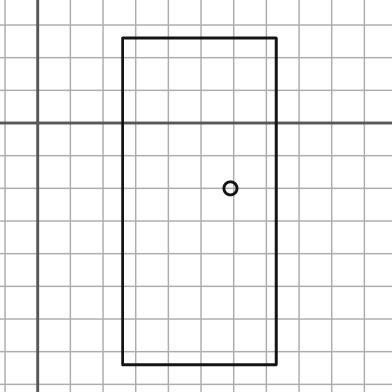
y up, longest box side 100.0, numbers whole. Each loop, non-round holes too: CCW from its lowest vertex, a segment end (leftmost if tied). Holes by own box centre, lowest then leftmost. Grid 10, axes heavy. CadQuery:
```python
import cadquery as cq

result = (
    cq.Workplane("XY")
    .moveTo(26.0, -74.0)
    .lineTo(73.0, -74.0)
    .lineTo(73.0, 26.0)
    .lineTo(26.0, 26.0)
    .close()
    .moveTo(59.0, -20.0)
    .circle(2.0)
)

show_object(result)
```